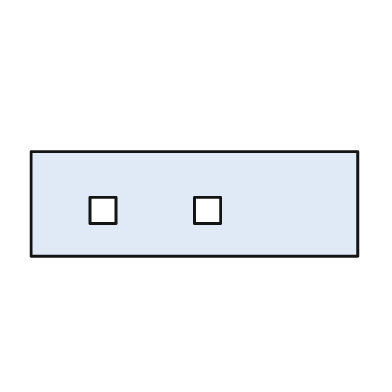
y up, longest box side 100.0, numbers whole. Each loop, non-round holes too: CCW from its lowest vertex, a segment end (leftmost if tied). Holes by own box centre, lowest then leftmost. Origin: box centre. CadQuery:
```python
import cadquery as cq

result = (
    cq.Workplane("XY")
    .moveTo(-50.0, -16.0)
    .lineTo(50.0, -16.0)
    .lineTo(50.0, 16.0)
    .lineTo(-50.0, 16.0)
    .close()
    .moveTo(-32.0, -6.0)
    .lineTo(-24.0, -6.0)
    .lineTo(-24.0, 2.0)
    .lineTo(-32.0, 2.0)
    .close()
    .moveTo(0.0, -6.0)
    .lineTo(8.0, -6.0)
    .lineTo(8.0, 2.0)
    .lineTo(0.0, 2.0)
    .close()
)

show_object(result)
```